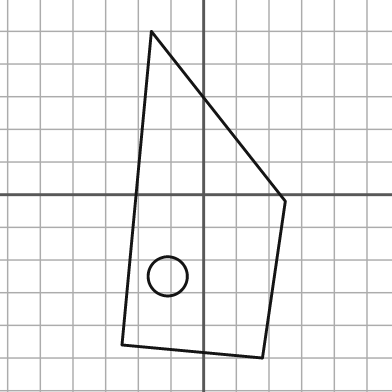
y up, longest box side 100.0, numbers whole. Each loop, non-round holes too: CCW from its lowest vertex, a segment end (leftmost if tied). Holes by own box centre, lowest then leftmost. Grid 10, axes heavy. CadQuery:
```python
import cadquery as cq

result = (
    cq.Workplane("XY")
    .moveTo(18.0, -50.0)
    .lineTo(25.0, -2.0)
    .lineTo(-16.0, 50.0)
    .lineTo(-25.0, -46.0)
    .close()
    .moveTo(-11.0, -25.0)
    .circle(6.0)
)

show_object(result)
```